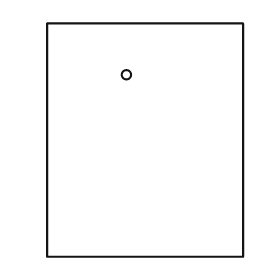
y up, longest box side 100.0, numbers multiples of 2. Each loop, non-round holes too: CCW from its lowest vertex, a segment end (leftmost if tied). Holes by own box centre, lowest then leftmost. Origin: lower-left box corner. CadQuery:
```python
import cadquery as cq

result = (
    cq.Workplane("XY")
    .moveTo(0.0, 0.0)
    .lineTo(84.0, 0.0)
    .lineTo(84.0, 100.0)
    .lineTo(0.0, 100.0)
    .close()
    .moveTo(34.0, 78.0)
    .circle(2.0)
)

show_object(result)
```